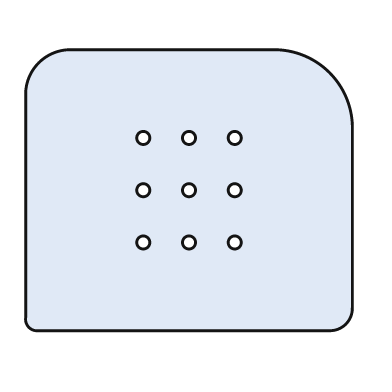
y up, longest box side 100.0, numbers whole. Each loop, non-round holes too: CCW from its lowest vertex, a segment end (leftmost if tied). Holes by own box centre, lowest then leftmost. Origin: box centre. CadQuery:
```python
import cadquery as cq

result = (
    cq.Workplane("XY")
    .moveTo(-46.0, -43.0)
    .lineTo(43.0, -43.0)
    .threePointArc((48.0, -41.0), (50.0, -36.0))
    .lineTo(50.0, 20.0)
    .threePointArc((43.0, 36.0), (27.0, 43.0))
    .lineTo(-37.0, 43.0)
    .threePointArc((-46.0, 39.0), (-50.0, 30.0))
    .lineTo(-50.0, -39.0)
    .threePointArc((-49.0, -42.0), (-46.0, -43.0))
    .close()
    .moveTo(-14.0, -16.0)
    .circle(2.0)
    .moveTo(0.0, -16.0)
    .circle(2.0)
    .moveTo(14.0, -16.0)
    .circle(2.0)
    .moveTo(-14.0, 0.0)
    .circle(2.0)
    .moveTo(0.0, 0.0)
    .circle(2.0)
    .moveTo(14.0, 0.0)
    .circle(2.0)
    .moveTo(-14.0, 16.0)
    .circle(2.0)
    .moveTo(0.0, 16.0)
    .circle(2.0)
    .moveTo(14.0, 16.0)
    .circle(2.0)
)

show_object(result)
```